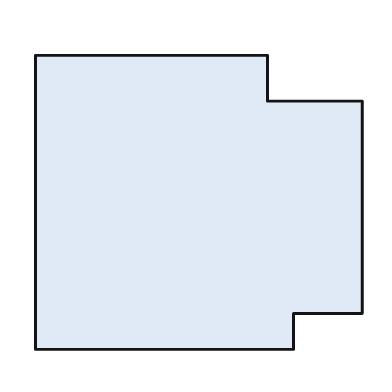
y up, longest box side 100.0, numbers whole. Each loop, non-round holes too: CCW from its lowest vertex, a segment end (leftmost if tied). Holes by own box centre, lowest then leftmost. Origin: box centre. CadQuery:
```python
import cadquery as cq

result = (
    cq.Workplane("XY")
    .moveTo(-50.0, -45.0)
    .lineTo(29.0, -45.0)
    .lineTo(29.0, -34.0)
    .lineTo(50.0, -34.0)
    .lineTo(50.0, 31.0)
    .lineTo(21.0, 31.0)
    .lineTo(21.0, 45.0)
    .lineTo(-50.0, 45.0)
    .close()
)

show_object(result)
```